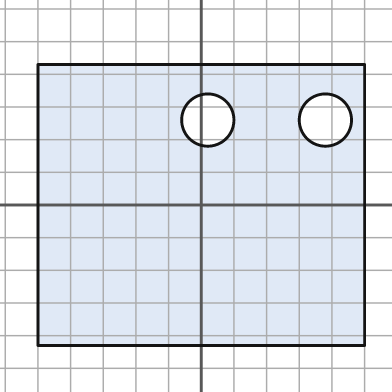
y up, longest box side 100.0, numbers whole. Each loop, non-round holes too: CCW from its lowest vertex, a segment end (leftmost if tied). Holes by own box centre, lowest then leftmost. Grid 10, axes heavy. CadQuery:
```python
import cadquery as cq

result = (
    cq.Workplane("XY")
    .moveTo(-50.0, -43.0)
    .lineTo(50.0, -43.0)
    .lineTo(50.0, 43.0)
    .lineTo(-50.0, 43.0)
    .close()
    .moveTo(2.0, 26.0)
    .circle(8.0)
    .moveTo(38.0, 26.0)
    .circle(8.0)
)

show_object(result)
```